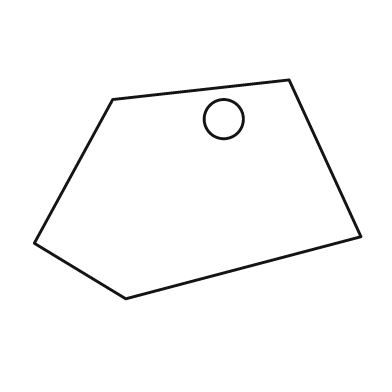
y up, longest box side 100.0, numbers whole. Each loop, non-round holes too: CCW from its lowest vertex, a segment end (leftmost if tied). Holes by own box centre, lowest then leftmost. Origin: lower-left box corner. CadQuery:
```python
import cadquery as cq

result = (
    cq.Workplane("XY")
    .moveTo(28.0, 0.0)
    .lineTo(100.0, 19.0)
    .lineTo(78.0, 67.0)
    .lineTo(24.0, 61.0)
    .lineTo(0.0, 17.0)
    .close()
    .moveTo(58.0, 55.0)
    .circle(6.0)
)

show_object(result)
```